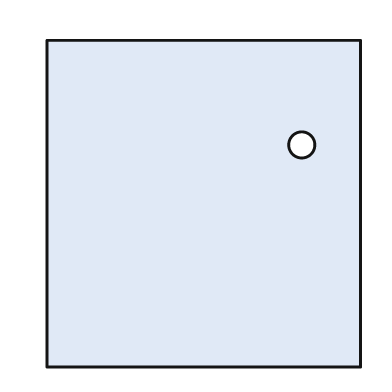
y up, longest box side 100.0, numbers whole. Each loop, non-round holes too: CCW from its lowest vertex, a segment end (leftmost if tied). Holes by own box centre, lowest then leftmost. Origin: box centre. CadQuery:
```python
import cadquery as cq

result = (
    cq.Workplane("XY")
    .moveTo(-48.0, -50.0)
    .lineTo(48.0, -50.0)
    .lineTo(48.0, 50.0)
    .lineTo(-48.0, 50.0)
    .close()
    .moveTo(30.0, 18.0)
    .circle(4.0)
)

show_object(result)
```